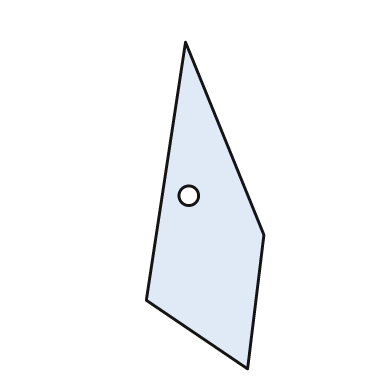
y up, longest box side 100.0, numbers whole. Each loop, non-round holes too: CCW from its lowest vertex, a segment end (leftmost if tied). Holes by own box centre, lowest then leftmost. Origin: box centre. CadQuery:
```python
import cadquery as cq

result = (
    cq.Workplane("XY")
    .moveTo(13.0, -50.0)
    .lineTo(18.0, -9.0)
    .lineTo(-6.0, 50.0)
    .lineTo(-18.0, -29.0)
    .close()
    .moveTo(-5.0, 3.0)
    .circle(3.0)
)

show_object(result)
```